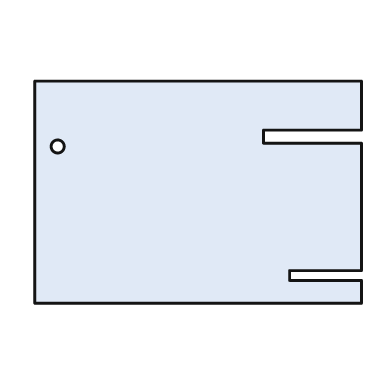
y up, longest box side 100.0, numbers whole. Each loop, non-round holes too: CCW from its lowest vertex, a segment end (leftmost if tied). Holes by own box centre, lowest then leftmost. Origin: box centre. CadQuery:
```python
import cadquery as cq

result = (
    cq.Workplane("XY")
    .moveTo(-50.0, -34.0)
    .lineTo(50.0, -34.0)
    .lineTo(50.0, -27.0)
    .lineTo(28.0, -27.0)
    .lineTo(28.0, -24.0)
    .lineTo(50.0, -24.0)
    .lineTo(50.0, 15.0)
    .lineTo(20.0, 15.0)
    .lineTo(20.0, 19.0)
    .lineTo(50.0, 19.0)
    .lineTo(50.0, 34.0)
    .lineTo(-50.0, 34.0)
    .close()
    .moveTo(-43.0, 14.0)
    .circle(2.0)
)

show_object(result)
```